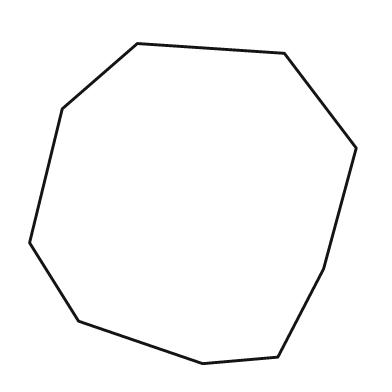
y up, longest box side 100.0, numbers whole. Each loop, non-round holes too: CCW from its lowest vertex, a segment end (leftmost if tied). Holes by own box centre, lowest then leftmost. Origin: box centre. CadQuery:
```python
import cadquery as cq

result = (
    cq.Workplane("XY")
    .moveTo(3.0, -49.0)
    .lineTo(26.0, -47.0)
    .lineTo(40.0, -20.0)
    .lineTo(50.0, 17.0)
    .lineTo(28.0, 46.0)
    .lineTo(-17.0, 49.0)
    .lineTo(-40.0, 29.0)
    .lineTo(-50.0, -12.0)
    .lineTo(-35.0, -36.0)
    .close()
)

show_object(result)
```